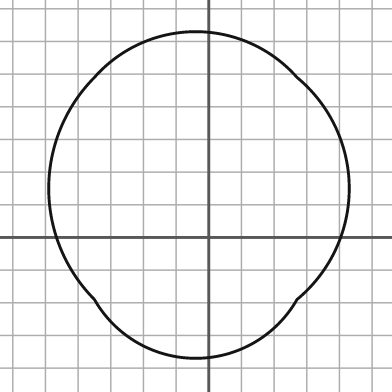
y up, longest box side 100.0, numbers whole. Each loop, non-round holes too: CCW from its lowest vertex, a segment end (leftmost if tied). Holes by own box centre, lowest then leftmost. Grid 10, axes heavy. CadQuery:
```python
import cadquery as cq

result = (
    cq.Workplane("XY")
    .moveTo(-35.0, -19.0)
    .threePointArc((-4.0, -37.0), (27.0, -19.0))
    .threePointArc((43.0, 15.0), (27.0, 49.0))
    .threePointArc((-4.0, 63.0), (-35.0, 49.0))
    .threePointArc((-49.0, 15.0), (-35.0, -19.0))
    .close()
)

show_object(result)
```